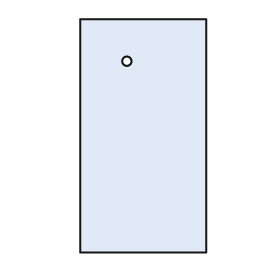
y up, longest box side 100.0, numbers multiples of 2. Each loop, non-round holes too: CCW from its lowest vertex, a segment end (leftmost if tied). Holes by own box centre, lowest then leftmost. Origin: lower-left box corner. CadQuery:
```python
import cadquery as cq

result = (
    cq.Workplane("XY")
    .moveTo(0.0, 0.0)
    .lineTo(54.0, 0.0)
    .lineTo(54.0, 100.0)
    .lineTo(0.0, 100.0)
    .close()
    .moveTo(20.0, 82.0)
    .circle(2.0)
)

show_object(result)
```